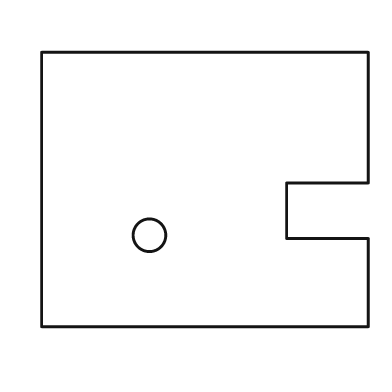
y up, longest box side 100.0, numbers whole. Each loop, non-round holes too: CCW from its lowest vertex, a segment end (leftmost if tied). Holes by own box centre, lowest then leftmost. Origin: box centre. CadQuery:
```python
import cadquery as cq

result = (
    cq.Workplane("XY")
    .moveTo(-50.0, -42.0)
    .lineTo(50.0, -42.0)
    .lineTo(50.0, -15.0)
    .lineTo(25.0, -15.0)
    .lineTo(25.0, 2.0)
    .lineTo(50.0, 2.0)
    .lineTo(50.0, 42.0)
    .lineTo(-50.0, 42.0)
    .close()
    .moveTo(-17.0, -14.0)
    .circle(5.0)
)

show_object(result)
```